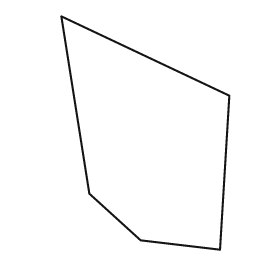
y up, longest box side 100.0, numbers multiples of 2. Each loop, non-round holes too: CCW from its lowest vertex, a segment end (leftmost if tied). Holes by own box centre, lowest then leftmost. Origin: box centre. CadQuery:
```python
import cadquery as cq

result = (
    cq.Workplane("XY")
    .moveTo(32.0, -50.0)
    .lineTo(36.0, 16.0)
    .lineTo(-36.0, 50.0)
    .lineTo(-24.0, -26.0)
    .lineTo(-2.0, -46.0)
    .close()
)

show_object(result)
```